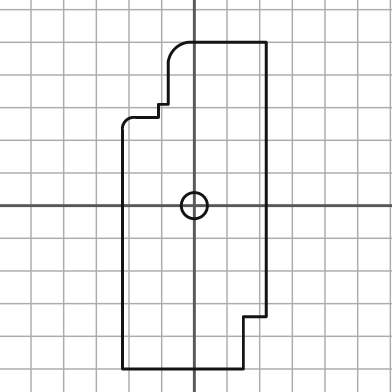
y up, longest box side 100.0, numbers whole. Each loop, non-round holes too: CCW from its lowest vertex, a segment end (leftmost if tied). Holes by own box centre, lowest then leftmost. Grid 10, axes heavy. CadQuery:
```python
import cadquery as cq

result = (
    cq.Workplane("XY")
    .moveTo(-22.0, -50.0)
    .lineTo(15.0, -50.0)
    .lineTo(15.0, -34.0)
    .lineTo(22.0, -34.0)
    .lineTo(22.0, 50.0)
    .lineTo(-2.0, 50.0)
    .threePointArc((-6.0, 48.0), (-8.0, 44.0))
    .lineTo(-8.0, 31.0)
    .lineTo(-11.0, 31.0)
    .lineTo(-11.0, 27.0)
    .lineTo(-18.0, 27.0)
    .threePointArc((-21.0, 26.0), (-22.0, 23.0))
    .close()
    .moveTo(0.0, 0.0)
    .circle(4.0)
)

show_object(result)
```